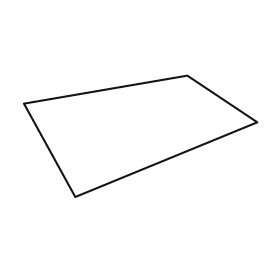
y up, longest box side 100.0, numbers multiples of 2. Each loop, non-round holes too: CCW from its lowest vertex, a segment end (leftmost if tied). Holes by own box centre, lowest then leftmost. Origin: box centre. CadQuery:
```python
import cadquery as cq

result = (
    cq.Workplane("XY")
    .moveTo(-28.0, -26.0)
    .lineTo(50.0, 6.0)
    .lineTo(20.0, 26.0)
    .lineTo(-50.0, 14.0)
    .close()
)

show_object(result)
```